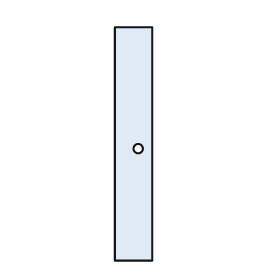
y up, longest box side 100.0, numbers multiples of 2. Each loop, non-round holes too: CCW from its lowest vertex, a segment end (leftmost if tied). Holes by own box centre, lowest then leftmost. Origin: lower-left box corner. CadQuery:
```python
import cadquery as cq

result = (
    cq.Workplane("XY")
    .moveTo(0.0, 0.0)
    .lineTo(16.0, 0.0)
    .lineTo(16.0, 100.0)
    .lineTo(0.0, 100.0)
    .close()
    .moveTo(10.0, 48.0)
    .circle(2.0)
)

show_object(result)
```